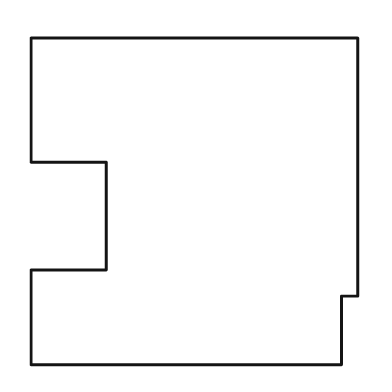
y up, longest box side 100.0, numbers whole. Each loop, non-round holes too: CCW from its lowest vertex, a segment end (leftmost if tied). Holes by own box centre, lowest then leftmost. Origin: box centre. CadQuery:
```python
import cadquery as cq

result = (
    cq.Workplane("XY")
    .moveTo(-50.0, -50.0)
    .lineTo(45.0, -50.0)
    .lineTo(45.0, -29.0)
    .lineTo(50.0, -29.0)
    .lineTo(50.0, 50.0)
    .lineTo(-50.0, 50.0)
    .lineTo(-50.0, 12.0)
    .lineTo(-27.0, 12.0)
    .lineTo(-27.0, -21.0)
    .lineTo(-50.0, -21.0)
    .close()
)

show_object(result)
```